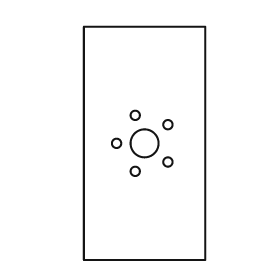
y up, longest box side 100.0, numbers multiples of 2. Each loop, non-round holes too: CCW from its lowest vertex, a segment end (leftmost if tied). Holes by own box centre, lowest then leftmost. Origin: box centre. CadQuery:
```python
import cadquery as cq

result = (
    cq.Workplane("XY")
    .moveTo(-26.0, -50.0)
    .lineTo(26.0, -50.0)
    .lineTo(26.0, 50.0)
    .lineTo(-26.0, 50.0)
    .close()
    .moveTo(-4.0, -12.0)
    .circle(2.0)
    .moveTo(10.0, -8.0)
    .circle(2.0)
    .moveTo(-12.0, 0.0)
    .circle(2.0)
    .moveTo(0.0, 0.0)
    .circle(6.0)
    .moveTo(10.0, 8.0)
    .circle(2.0)
    .moveTo(-4.0, 12.0)
    .circle(2.0)
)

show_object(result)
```